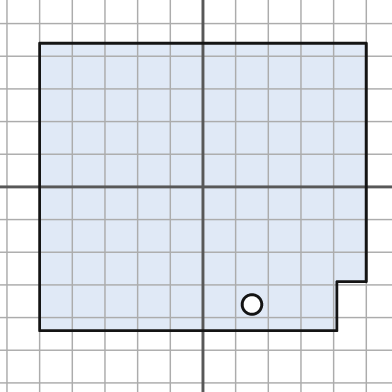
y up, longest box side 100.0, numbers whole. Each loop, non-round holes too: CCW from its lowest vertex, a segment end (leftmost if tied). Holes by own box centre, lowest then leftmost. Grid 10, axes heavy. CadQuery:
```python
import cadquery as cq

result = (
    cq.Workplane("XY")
    .moveTo(-50.0, -44.0)
    .lineTo(41.0, -44.0)
    .lineTo(41.0, -29.0)
    .lineTo(50.0, -29.0)
    .lineTo(50.0, 44.0)
    .lineTo(-50.0, 44.0)
    .close()
    .moveTo(15.0, -36.0)
    .circle(3.0)
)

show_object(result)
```